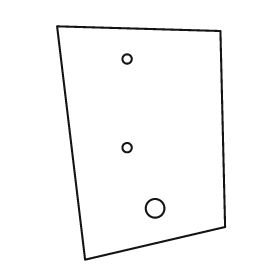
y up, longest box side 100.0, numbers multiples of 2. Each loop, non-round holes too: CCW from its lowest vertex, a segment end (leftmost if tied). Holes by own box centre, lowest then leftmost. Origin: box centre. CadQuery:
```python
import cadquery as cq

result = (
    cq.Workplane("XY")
    .moveTo(-24.0, -50.0)
    .lineTo(36.0, -36.0)
    .lineTo(34.0, 48.0)
    .lineTo(-36.0, 50.0)
    .close()
    .moveTo(6.0, -28.0)
    .circle(4.0)
    .moveTo(-6.0, -2.0)
    .circle(2.0)
    .moveTo(-6.0, 36.0)
    .circle(2.0)
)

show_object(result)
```